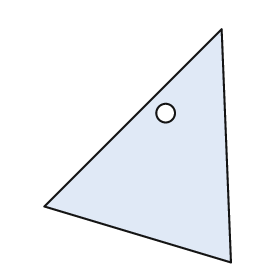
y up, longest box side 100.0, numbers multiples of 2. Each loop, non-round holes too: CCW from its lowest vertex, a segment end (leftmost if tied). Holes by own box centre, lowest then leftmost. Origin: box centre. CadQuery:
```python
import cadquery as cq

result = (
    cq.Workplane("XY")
    .moveTo(40.0, -50.0)
    .lineTo(36.0, 50.0)
    .lineTo(-40.0, -26.0)
    .close()
    .moveTo(12.0, 14.0)
    .circle(4.0)
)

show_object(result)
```